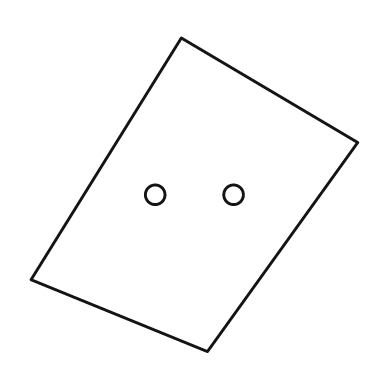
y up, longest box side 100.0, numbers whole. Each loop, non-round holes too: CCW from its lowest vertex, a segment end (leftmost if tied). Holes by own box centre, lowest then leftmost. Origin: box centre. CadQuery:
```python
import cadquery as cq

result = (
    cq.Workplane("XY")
    .moveTo(4.0, -48.0)
    .lineTo(50.0, 16.0)
    .lineTo(-4.0, 48.0)
    .lineTo(-50.0, -26.0)
    .close()
    .moveTo(-12.0, 0.0)
    .circle(3.0)
    .moveTo(12.0, 0.0)
    .circle(3.0)
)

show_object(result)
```